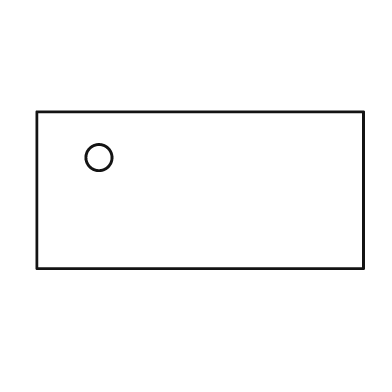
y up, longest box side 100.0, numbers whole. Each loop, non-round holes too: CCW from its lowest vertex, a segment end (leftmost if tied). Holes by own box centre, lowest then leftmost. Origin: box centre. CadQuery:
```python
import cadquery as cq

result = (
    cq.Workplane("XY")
    .moveTo(-50.0, -24.0)
    .lineTo(50.0, -24.0)
    .lineTo(50.0, 24.0)
    .lineTo(-50.0, 24.0)
    .close()
    .moveTo(-31.0, 10.0)
    .circle(4.0)
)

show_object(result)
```